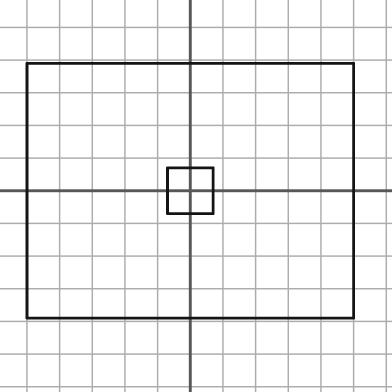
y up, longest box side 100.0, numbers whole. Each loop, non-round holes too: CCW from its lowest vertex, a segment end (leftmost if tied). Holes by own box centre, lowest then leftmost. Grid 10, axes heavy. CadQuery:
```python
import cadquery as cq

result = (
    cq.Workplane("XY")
    .moveTo(-50.0, -39.0)
    .lineTo(50.0, -39.0)
    .lineTo(50.0, 39.0)
    .lineTo(-50.0, 39.0)
    .close()
    .moveTo(-7.0, -7.0)
    .lineTo(7.0, -7.0)
    .lineTo(7.0, 7.0)
    .lineTo(-7.0, 7.0)
    .close()
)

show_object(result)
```